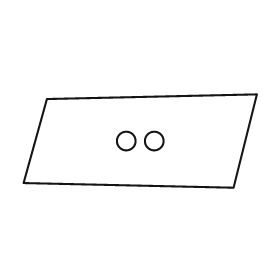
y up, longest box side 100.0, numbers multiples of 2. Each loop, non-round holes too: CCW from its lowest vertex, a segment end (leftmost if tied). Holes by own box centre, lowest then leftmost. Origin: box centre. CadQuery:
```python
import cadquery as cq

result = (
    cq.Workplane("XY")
    .moveTo(40.0, -20.0)
    .lineTo(50.0, 20.0)
    .lineTo(-40.0, 18.0)
    .lineTo(-50.0, -18.0)
    .close()
    .moveTo(-6.0, 0.0)
    .circle(4.0)
    .moveTo(6.0, 0.0)
    .circle(4.0)
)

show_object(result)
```